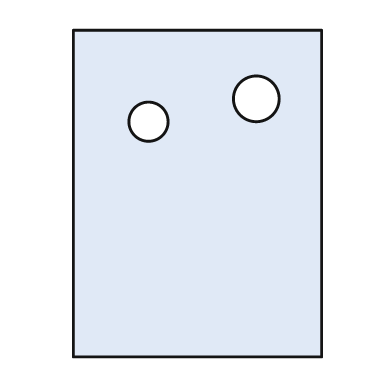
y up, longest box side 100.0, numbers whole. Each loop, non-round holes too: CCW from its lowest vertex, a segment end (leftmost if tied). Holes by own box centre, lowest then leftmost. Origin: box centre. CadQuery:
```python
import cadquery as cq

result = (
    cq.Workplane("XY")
    .moveTo(-38.0, -50.0)
    .lineTo(38.0, -50.0)
    .lineTo(38.0, 50.0)
    .lineTo(-38.0, 50.0)
    .close()
    .moveTo(-15.0, 22.0)
    .circle(6.0)
    .moveTo(18.0, 29.0)
    .circle(7.0)
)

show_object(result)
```